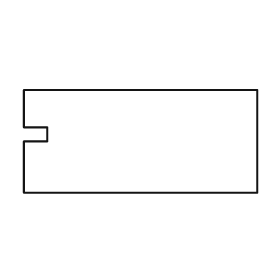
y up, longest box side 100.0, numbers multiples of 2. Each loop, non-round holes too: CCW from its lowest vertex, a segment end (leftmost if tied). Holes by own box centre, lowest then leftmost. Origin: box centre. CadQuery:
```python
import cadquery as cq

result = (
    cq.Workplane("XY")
    .moveTo(-50.0, -22.0)
    .lineTo(50.0, -22.0)
    .lineTo(50.0, 22.0)
    .lineTo(-50.0, 22.0)
    .lineTo(-50.0, 6.0)
    .lineTo(-40.0, 6.0)
    .lineTo(-40.0, 0.0)
    .lineTo(-50.0, 0.0)
    .close()
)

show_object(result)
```